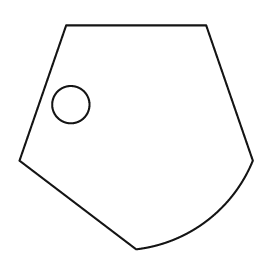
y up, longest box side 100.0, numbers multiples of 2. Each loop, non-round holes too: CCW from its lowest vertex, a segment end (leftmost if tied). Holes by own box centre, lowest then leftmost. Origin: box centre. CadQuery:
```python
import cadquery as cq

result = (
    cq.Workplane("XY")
    .moveTo(0.0, -48.0)
    .threePointArc((30.0, -36.0), (50.0, -10.0))
    .lineTo(30.0, 48.0)
    .lineTo(-30.0, 48.0)
    .lineTo(-50.0, -10.0)
    .close()
    .moveTo(-28.0, 14.0)
    .circle(8.0)
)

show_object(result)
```